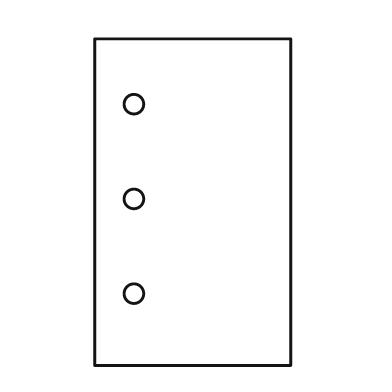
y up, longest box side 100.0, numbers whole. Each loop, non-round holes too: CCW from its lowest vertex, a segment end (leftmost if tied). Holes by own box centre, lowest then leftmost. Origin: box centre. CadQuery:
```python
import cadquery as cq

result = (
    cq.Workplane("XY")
    .moveTo(-30.0, -50.0)
    .lineTo(30.0, -50.0)
    .lineTo(30.0, 50.0)
    .lineTo(-30.0, 50.0)
    .close()
    .moveTo(-18.0, -28.0)
    .circle(3.0)
    .moveTo(-18.0, 1.0)
    .circle(3.0)
    .moveTo(-18.0, 30.0)
    .circle(3.0)
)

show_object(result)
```